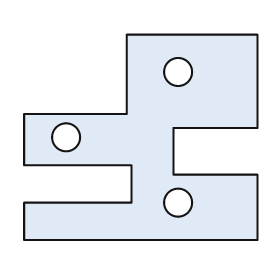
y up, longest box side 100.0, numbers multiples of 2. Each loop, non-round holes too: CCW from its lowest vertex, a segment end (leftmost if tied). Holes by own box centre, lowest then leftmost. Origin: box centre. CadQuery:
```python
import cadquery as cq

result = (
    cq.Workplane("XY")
    .moveTo(-50.0, -44.0)
    .lineTo(50.0, -44.0)
    .lineTo(50.0, -16.0)
    .lineTo(14.0, -16.0)
    .lineTo(14.0, 4.0)
    .lineTo(50.0, 4.0)
    .lineTo(50.0, 44.0)
    .lineTo(-6.0, 44.0)
    .lineTo(-6.0, 10.0)
    .lineTo(-50.0, 10.0)
    .lineTo(-50.0, -12.0)
    .lineTo(-4.0, -12.0)
    .lineTo(-4.0, -28.0)
    .lineTo(-50.0, -28.0)
    .close()
    .moveTo(16.0, -28.0)
    .circle(6.0)
    .moveTo(-32.0, 0.0)
    .circle(6.0)
    .moveTo(16.0, 28.0)
    .circle(6.0)
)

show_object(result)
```